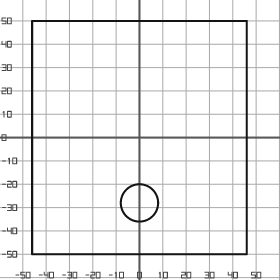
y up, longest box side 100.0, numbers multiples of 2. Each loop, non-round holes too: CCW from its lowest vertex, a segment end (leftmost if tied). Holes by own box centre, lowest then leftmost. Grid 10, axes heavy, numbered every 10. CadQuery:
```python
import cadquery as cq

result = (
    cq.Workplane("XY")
    .moveTo(-46.0, -50.0)
    .lineTo(46.0, -50.0)
    .lineTo(46.0, 50.0)
    .lineTo(-46.0, 50.0)
    .close()
    .moveTo(0.0, -28.0)
    .circle(8.0)
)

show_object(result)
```